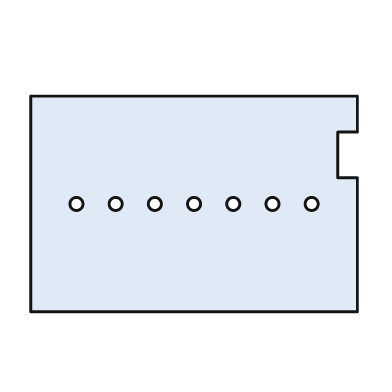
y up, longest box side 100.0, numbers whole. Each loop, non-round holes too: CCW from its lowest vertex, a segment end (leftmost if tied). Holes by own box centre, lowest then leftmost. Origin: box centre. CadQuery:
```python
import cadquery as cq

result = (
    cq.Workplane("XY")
    .moveTo(-50.0, -33.0)
    .lineTo(50.0, -33.0)
    .lineTo(50.0, 8.0)
    .lineTo(44.0, 8.0)
    .lineTo(44.0, 22.0)
    .lineTo(50.0, 22.0)
    .lineTo(50.0, 33.0)
    .lineTo(-50.0, 33.0)
    .close()
    .moveTo(-36.0, 0.0)
    .circle(2.0)
    .moveTo(-24.0, 0.0)
    .circle(2.0)
    .moveTo(-12.0, 0.0)
    .circle(2.0)
    .moveTo(0.0, 0.0)
    .circle(2.0)
    .moveTo(12.0, 0.0)
    .circle(2.0)
    .moveTo(24.0, 0.0)
    .circle(2.0)
    .moveTo(36.0, 0.0)
    .circle(2.0)
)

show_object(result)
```